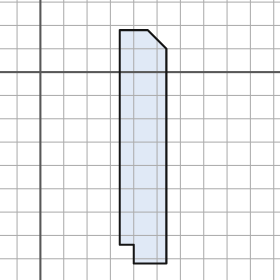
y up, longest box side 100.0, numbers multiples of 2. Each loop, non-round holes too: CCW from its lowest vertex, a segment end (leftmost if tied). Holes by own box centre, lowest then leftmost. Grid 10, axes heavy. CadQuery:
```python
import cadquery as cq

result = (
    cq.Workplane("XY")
    .moveTo(40.0, -82.0)
    .lineTo(54.0, -82.0)
    .lineTo(54.0, 10.0)
    .lineTo(46.0, 18.0)
    .lineTo(34.0, 18.0)
    .lineTo(34.0, -74.0)
    .lineTo(40.0, -74.0)
    .close()
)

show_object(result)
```